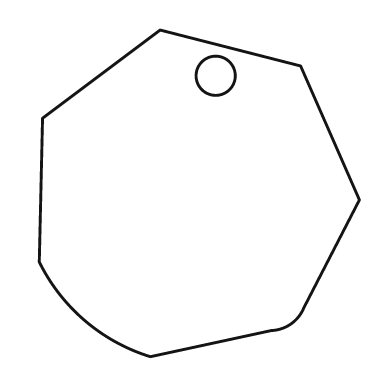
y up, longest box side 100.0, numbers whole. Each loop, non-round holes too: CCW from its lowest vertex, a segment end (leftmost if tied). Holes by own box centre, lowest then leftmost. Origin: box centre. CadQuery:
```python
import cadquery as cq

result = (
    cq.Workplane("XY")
    .moveTo(-15.0, -50.0)
    .lineTo(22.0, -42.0)
    .threePointArc((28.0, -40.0), (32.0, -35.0))
    .lineTo(49.0, -2.0)
    .lineTo(31.0, 39.0)
    .lineTo(-12.0, 50.0)
    .lineTo(-48.0, 23.0)
    .lineTo(-49.0, -21.0)
    .threePointArc((-35.0, -39.0), (-15.0, -50.0))
    .close()
    .moveTo(5.0, 36.0)
    .circle(6.0)
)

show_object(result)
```